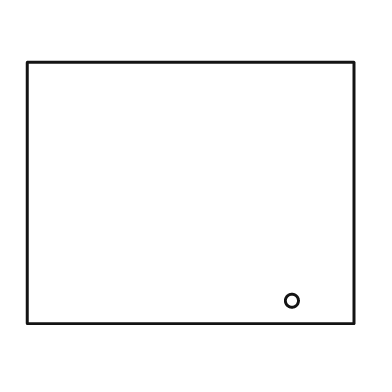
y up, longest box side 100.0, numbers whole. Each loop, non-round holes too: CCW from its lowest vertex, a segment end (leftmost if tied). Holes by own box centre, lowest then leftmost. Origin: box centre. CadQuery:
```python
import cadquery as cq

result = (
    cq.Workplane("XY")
    .moveTo(-50.0, -40.0)
    .lineTo(50.0, -40.0)
    .lineTo(50.0, 40.0)
    .lineTo(-50.0, 40.0)
    .close()
    .moveTo(31.0, -33.0)
    .circle(2.0)
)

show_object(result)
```